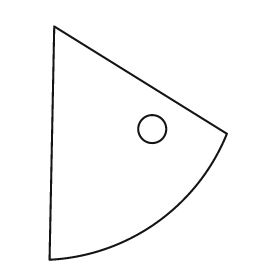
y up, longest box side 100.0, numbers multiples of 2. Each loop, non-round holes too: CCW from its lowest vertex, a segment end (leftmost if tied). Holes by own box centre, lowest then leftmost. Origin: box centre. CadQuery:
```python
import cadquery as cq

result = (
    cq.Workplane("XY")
    .moveTo(-38.0, -50.0)
    .threePointArc((8.0, -34.0), (38.0, 4.0))
    .lineTo(-36.0, 50.0)
    .close()
    .moveTo(6.0, 6.0)
    .circle(6.0)
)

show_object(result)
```